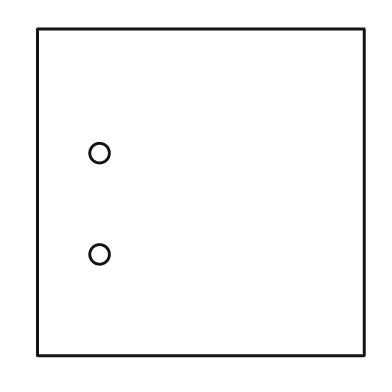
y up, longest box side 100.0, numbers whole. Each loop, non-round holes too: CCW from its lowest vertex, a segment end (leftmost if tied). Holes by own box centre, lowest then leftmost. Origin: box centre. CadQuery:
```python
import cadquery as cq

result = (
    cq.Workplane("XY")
    .moveTo(-50.0, -50.0)
    .lineTo(50.0, -50.0)
    .lineTo(50.0, 50.0)
    .lineTo(-50.0, 50.0)
    .close()
    .moveTo(-31.0, -19.0)
    .circle(3.0)
    .moveTo(-31.0, 12.0)
    .circle(3.0)
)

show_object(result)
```